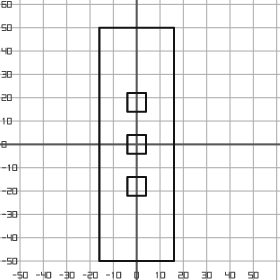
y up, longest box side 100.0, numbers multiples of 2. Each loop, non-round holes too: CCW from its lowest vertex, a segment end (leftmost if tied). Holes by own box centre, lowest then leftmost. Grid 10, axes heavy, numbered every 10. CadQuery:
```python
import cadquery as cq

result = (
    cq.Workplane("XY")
    .moveTo(-16.0, -50.0)
    .lineTo(16.0, -50.0)
    .lineTo(16.0, 50.0)
    .lineTo(-16.0, 50.0)
    .close()
    .moveTo(-4.0, -22.0)
    .lineTo(4.0, -22.0)
    .lineTo(4.0, -14.0)
    .lineTo(-4.0, -14.0)
    .close()
    .moveTo(-4.0, -4.0)
    .lineTo(4.0, -4.0)
    .lineTo(4.0, 4.0)
    .lineTo(-4.0, 4.0)
    .close()
    .moveTo(-4.0, 14.0)
    .lineTo(4.0, 14.0)
    .lineTo(4.0, 22.0)
    .lineTo(-4.0, 22.0)
    .close()
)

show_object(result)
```